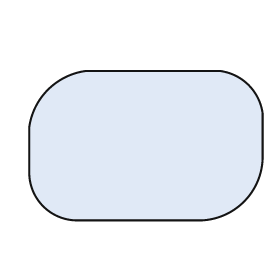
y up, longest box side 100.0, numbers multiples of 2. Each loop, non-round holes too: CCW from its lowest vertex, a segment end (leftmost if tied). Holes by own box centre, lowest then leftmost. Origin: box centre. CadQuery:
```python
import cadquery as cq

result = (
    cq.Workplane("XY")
    .moveTo(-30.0, -32.0)
    .lineTo(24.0, -32.0)
    .threePointArc((42.0, -24.0), (50.0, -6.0))
    .lineTo(50.0, 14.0)
    .threePointArc((44.0, 26.0), (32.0, 32.0))
    .lineTo(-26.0, 32.0)
    .threePointArc((-42.0, 24.0), (-50.0, 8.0))
    .lineTo(-50.0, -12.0)
    .threePointArc((-44.0, -26.0), (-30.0, -32.0))
    .close()
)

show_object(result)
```